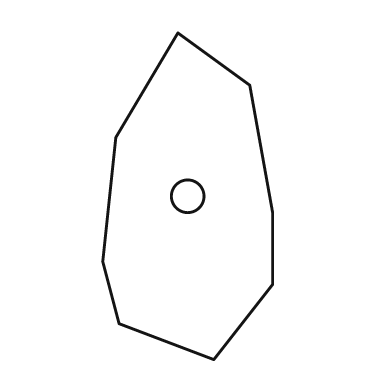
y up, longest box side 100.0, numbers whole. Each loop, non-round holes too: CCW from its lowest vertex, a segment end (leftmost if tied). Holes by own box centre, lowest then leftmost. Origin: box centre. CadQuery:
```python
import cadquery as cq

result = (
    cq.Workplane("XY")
    .moveTo(8.0, -50.0)
    .lineTo(26.0, -27.0)
    .lineTo(26.0, -5.0)
    .lineTo(19.0, 34.0)
    .lineTo(-3.0, 50.0)
    .lineTo(-22.0, 18.0)
    .lineTo(-26.0, -20.0)
    .lineTo(-21.0, -39.0)
    .close()
    .moveTo(0.0, 0.0)
    .circle(5.0)
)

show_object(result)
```